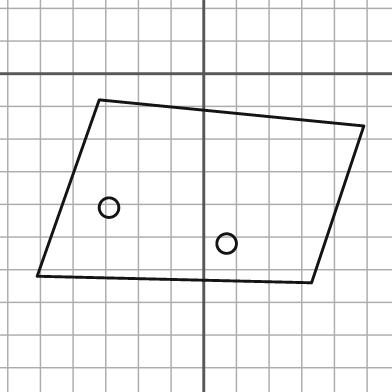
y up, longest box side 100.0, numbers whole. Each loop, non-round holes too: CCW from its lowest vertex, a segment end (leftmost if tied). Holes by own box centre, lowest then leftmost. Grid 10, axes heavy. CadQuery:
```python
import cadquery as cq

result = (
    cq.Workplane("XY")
    .moveTo(33.0, -64.0)
    .lineTo(49.0, -16.0)
    .lineTo(-32.0, -8.0)
    .lineTo(-51.0, -62.0)
    .close()
    .moveTo(7.0, -52.0)
    .circle(3.0)
    .moveTo(-29.0, -41.0)
    .circle(3.0)
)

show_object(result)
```